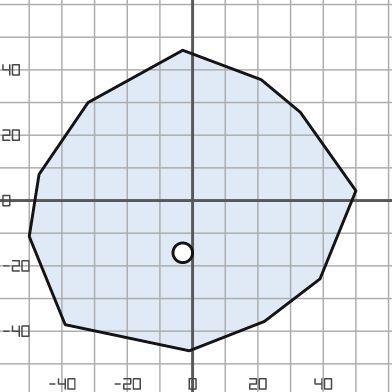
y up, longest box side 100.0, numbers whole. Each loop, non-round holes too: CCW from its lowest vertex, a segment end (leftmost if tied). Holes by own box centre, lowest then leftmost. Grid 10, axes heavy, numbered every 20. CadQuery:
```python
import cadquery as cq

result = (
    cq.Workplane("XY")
    .moveTo(-1.0, -46.0)
    .lineTo(22.0, -37.0)
    .lineTo(39.0, -24.0)
    .lineTo(50.0, 3.0)
    .lineTo(33.0, 27.0)
    .lineTo(21.0, 37.0)
    .lineTo(-3.0, 46.0)
    .lineTo(-32.0, 30.0)
    .lineTo(-47.0, 8.0)
    .lineTo(-50.0, -11.0)
    .lineTo(-39.0, -38.0)
    .close()
    .moveTo(-3.0, -16.0)
    .circle(3.0)
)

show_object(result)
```